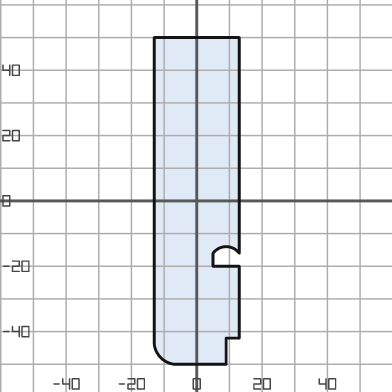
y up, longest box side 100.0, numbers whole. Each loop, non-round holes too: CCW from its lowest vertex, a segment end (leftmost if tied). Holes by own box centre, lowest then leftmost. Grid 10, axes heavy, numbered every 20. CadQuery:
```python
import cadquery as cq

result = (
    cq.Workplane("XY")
    .moveTo(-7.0, -50.0)
    .lineTo(9.0, -50.0)
    .lineTo(9.0, -42.0)
    .lineTo(13.0, -42.0)
    .lineTo(13.0, -20.0)
    .lineTo(5.0, -20.0)
    .lineTo(5.0, -16.0)
    .threePointArc((9.0, -14.0), (13.0, -16.0))
    .lineTo(13.0, 50.0)
    .lineTo(-13.0, 50.0)
    .lineTo(-13.0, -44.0)
    .threePointArc((-11.0, -48.0), (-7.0, -50.0))
    .close()
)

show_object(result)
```